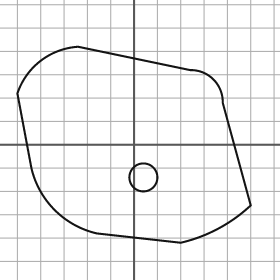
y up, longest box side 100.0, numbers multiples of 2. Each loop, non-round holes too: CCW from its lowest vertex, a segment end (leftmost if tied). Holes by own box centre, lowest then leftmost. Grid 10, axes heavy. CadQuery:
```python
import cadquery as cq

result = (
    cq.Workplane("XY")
    .moveTo(20.0, -42.0)
    .threePointArc((36.0, -36.0), (50.0, -26.0))
    .lineTo(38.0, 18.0)
    .threePointArc((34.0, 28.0), (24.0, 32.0))
    .lineTo(-24.0, 42.0)
    .threePointArc((-40.0, 36.0), (-50.0, 22.0))
    .lineTo(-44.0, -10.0)
    .threePointArc((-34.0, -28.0), (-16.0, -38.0))
    .close()
    .moveTo(4.0, -14.0)
    .circle(6.0)
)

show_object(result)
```